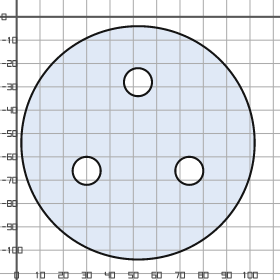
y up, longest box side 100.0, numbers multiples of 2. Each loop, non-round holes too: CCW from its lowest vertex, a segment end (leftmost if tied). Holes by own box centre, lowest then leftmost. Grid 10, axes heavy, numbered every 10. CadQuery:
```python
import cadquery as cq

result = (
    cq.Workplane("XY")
    .moveTo(52.0, -54.0)
    .circle(50.0)
    .moveTo(30.0, -66.0)
    .circle(6.0)
    .moveTo(74.0, -66.0)
    .circle(6.0)
    .moveTo(52.0, -28.0)
    .circle(6.0)
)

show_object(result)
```